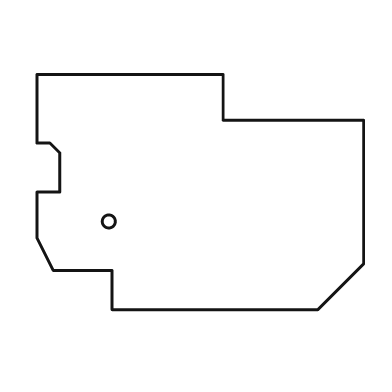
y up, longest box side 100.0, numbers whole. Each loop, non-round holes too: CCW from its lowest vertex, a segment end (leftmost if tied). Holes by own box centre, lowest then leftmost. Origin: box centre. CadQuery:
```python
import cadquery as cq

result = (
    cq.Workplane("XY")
    .moveTo(-27.0, -36.0)
    .lineTo(36.0, -36.0)
    .lineTo(50.0, -22.0)
    .lineTo(50.0, 22.0)
    .lineTo(7.0, 22.0)
    .lineTo(7.0, 36.0)
    .lineTo(-50.0, 36.0)
    .lineTo(-50.0, 15.0)
    .lineTo(-46.0, 15.0)
    .lineTo(-43.0, 12.0)
    .lineTo(-43.0, 0.0)
    .lineTo(-50.0, 0.0)
    .lineTo(-50.0, -14.0)
    .lineTo(-45.0, -24.0)
    .lineTo(-27.0, -24.0)
    .close()
    .moveTo(-28.0, -9.0)
    .circle(2.0)
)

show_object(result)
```